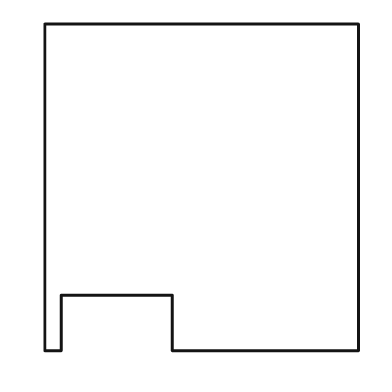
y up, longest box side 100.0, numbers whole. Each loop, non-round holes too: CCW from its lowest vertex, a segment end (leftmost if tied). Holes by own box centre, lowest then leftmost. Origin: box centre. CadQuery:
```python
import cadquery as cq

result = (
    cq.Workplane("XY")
    .moveTo(-48.0, -50.0)
    .lineTo(-43.0, -50.0)
    .lineTo(-43.0, -33.0)
    .lineTo(-9.0, -33.0)
    .lineTo(-9.0, -50.0)
    .lineTo(48.0, -50.0)
    .lineTo(48.0, 50.0)
    .lineTo(-48.0, 50.0)
    .close()
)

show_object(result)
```